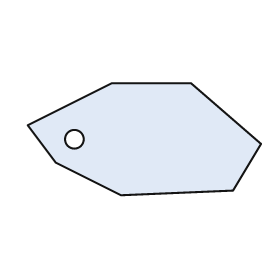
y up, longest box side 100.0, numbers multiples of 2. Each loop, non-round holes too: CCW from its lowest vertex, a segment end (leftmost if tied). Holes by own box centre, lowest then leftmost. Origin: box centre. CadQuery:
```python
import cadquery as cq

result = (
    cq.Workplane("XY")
    .moveTo(-10.0, -24.0)
    .lineTo(38.0, -22.0)
    .lineTo(50.0, -2.0)
    .lineTo(20.0, 24.0)
    .lineTo(-14.0, 24.0)
    .lineTo(-50.0, 6.0)
    .lineTo(-38.0, -10.0)
    .close()
    .moveTo(-30.0, 0.0)
    .circle(4.0)
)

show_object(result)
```